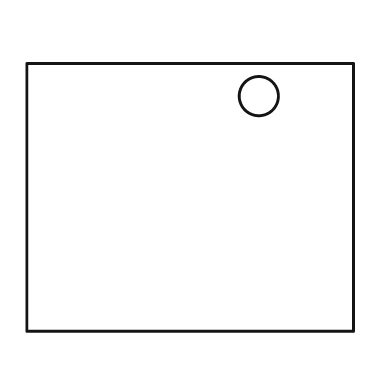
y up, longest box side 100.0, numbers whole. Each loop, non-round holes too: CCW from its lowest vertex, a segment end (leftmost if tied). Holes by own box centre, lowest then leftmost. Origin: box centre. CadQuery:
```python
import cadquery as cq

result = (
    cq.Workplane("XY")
    .moveTo(-50.0, -41.0)
    .lineTo(50.0, -41.0)
    .lineTo(50.0, 41.0)
    .lineTo(-50.0, 41.0)
    .close()
    .moveTo(21.0, 31.0)
    .circle(6.0)
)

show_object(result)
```